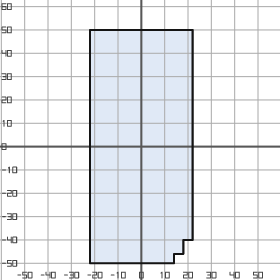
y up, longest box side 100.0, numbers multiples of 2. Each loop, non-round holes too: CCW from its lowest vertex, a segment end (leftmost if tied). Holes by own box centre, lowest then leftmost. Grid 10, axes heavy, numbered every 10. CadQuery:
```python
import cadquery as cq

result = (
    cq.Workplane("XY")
    .moveTo(-22.0, -50.0)
    .lineTo(14.0, -50.0)
    .lineTo(14.0, -46.0)
    .lineTo(18.0, -46.0)
    .lineTo(18.0, -40.0)
    .lineTo(22.0, -40.0)
    .lineTo(22.0, 50.0)
    .lineTo(-22.0, 50.0)
    .close()
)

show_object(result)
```